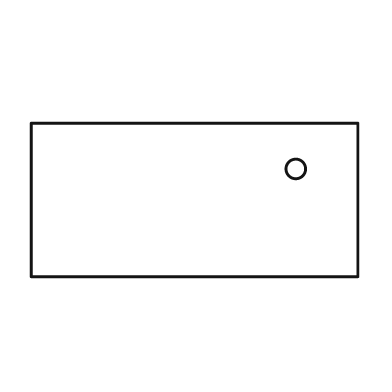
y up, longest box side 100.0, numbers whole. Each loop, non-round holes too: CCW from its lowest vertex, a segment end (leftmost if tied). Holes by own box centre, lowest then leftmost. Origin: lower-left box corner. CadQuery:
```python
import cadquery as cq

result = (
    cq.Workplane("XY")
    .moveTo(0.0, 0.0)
    .lineTo(100.0, 0.0)
    .lineTo(100.0, 47.0)
    .lineTo(0.0, 47.0)
    .close()
    .moveTo(81.0, 33.0)
    .circle(3.0)
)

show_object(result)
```